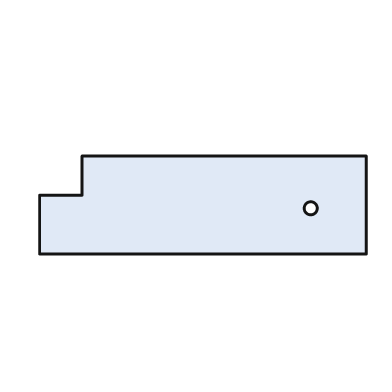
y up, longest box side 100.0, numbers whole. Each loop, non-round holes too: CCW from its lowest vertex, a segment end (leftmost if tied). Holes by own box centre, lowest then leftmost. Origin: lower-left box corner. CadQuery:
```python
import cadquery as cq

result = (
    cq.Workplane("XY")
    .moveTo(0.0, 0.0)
    .lineTo(100.0, 0.0)
    .lineTo(100.0, 30.0)
    .lineTo(13.0, 30.0)
    .lineTo(13.0, 18.0)
    .lineTo(0.0, 18.0)
    .close()
    .moveTo(83.0, 14.0)
    .circle(2.0)
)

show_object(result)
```